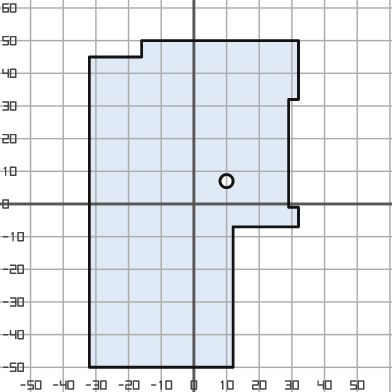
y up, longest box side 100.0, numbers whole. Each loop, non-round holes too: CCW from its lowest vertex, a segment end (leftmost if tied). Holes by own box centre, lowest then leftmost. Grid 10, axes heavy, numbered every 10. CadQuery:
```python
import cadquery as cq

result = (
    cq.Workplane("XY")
    .moveTo(-32.0, -50.0)
    .lineTo(12.0, -50.0)
    .lineTo(12.0, -7.0)
    .lineTo(32.0, -7.0)
    .lineTo(32.0, -1.0)
    .lineTo(29.0, -1.0)
    .lineTo(29.0, 32.0)
    .lineTo(32.0, 32.0)
    .lineTo(32.0, 50.0)
    .lineTo(-16.0, 50.0)
    .lineTo(-16.0, 45.0)
    .lineTo(-32.0, 45.0)
    .close()
    .moveTo(10.0, 7.0)
    .circle(2.0)
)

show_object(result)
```